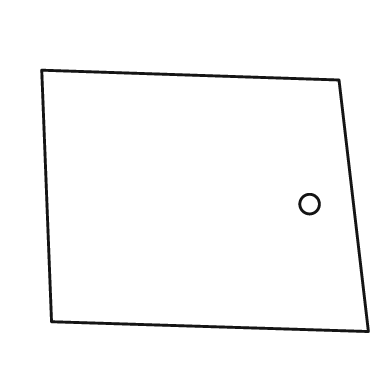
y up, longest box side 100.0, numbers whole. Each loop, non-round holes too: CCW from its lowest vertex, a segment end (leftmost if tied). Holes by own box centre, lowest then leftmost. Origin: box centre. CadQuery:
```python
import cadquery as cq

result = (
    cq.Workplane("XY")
    .moveTo(50.0, -40.0)
    .lineTo(41.0, 37.0)
    .lineTo(-50.0, 40.0)
    .lineTo(-47.0, -37.0)
    .close()
    .moveTo(32.0, -1.0)
    .circle(3.0)
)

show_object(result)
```